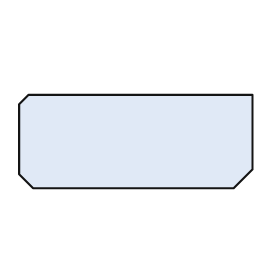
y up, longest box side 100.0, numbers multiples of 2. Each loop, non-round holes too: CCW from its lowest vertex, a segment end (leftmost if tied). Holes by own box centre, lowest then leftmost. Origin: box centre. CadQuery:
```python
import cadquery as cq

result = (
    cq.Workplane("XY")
    .moveTo(-44.0, -20.0)
    .lineTo(42.0, -20.0)
    .lineTo(50.0, -12.0)
    .lineTo(50.0, 20.0)
    .lineTo(-46.0, 20.0)
    .lineTo(-50.0, 16.0)
    .lineTo(-50.0, -14.0)
    .close()
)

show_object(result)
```